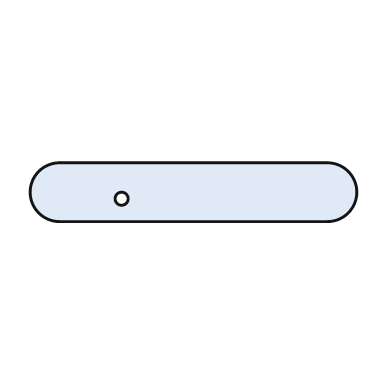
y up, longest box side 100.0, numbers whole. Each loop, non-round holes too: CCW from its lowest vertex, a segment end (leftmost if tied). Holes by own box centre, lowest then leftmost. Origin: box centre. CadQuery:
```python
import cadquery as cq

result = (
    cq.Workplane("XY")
    .moveTo(-41.0, -9.0)
    .lineTo(41.0, -9.0)
    .threePointArc((50.0, 0.0), (41.0, 9.0))
    .lineTo(-41.0, 9.0)
    .threePointArc((-50.0, 0.0), (-41.0, -9.0))
    .close()
    .moveTo(-22.0, -2.0)
    .circle(2.0)
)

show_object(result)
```